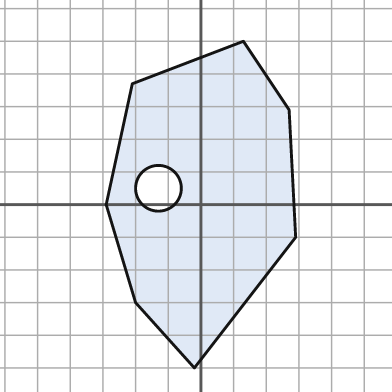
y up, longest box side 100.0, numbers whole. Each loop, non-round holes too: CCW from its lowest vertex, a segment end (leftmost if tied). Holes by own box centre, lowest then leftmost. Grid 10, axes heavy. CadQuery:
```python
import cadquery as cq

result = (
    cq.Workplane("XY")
    .moveTo(-2.0, -50.0)
    .lineTo(29.0, -10.0)
    .lineTo(27.0, 29.0)
    .lineTo(13.0, 50.0)
    .lineTo(-21.0, 37.0)
    .lineTo(-29.0, 0.0)
    .lineTo(-20.0, -30.0)
    .close()
    .moveTo(-13.0, 5.0)
    .circle(7.0)
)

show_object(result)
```